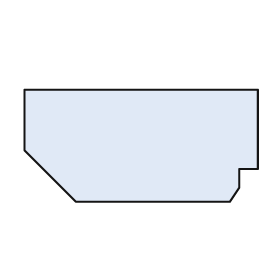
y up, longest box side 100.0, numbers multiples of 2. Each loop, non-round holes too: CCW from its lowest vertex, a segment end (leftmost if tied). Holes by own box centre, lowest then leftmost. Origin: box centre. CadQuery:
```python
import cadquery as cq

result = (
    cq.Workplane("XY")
    .moveTo(-28.0, -24.0)
    .lineTo(38.0, -24.0)
    .lineTo(42.0, -18.0)
    .lineTo(42.0, -10.0)
    .lineTo(50.0, -10.0)
    .lineTo(50.0, 24.0)
    .lineTo(-50.0, 24.0)
    .lineTo(-50.0, -2.0)
    .close()
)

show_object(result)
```